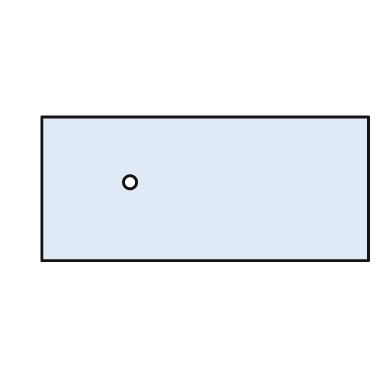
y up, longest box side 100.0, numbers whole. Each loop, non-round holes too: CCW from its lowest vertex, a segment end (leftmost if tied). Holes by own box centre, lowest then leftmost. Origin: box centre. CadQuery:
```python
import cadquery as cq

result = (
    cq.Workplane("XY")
    .moveTo(-50.0, -22.0)
    .lineTo(50.0, -22.0)
    .lineTo(50.0, 22.0)
    .lineTo(-50.0, 22.0)
    .close()
    .moveTo(-23.0, 2.0)
    .circle(2.0)
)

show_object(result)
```